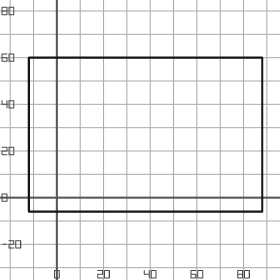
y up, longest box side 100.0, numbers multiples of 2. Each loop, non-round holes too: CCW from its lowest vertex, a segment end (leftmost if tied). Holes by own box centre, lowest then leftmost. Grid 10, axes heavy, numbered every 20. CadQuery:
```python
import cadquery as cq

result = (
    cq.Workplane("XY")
    .moveTo(-12.0, -6.0)
    .lineTo(88.0, -6.0)
    .lineTo(88.0, 60.0)
    .lineTo(-12.0, 60.0)
    .close()
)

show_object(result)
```